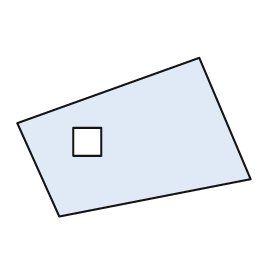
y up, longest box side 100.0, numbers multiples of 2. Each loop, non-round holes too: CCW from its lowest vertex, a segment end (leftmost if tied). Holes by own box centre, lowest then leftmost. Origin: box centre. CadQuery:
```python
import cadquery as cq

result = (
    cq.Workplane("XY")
    .moveTo(-32.0, -34.0)
    .lineTo(50.0, -18.0)
    .lineTo(28.0, 34.0)
    .lineTo(-50.0, 6.0)
    .close()
    .moveTo(-26.0, -8.0)
    .lineTo(-14.0, -8.0)
    .lineTo(-14.0, 4.0)
    .lineTo(-26.0, 4.0)
    .close()
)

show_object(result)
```